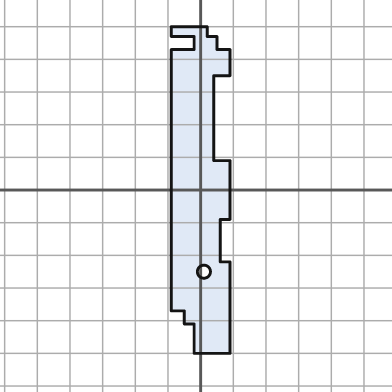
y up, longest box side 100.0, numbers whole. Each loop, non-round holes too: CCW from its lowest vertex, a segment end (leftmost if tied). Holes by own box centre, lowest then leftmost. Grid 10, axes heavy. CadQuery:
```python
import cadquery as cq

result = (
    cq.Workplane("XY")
    .moveTo(-2.0, -50.0)
    .lineTo(9.0, -50.0)
    .lineTo(9.0, -22.0)
    .lineTo(6.0, -22.0)
    .lineTo(6.0, -9.0)
    .lineTo(9.0, -9.0)
    .lineTo(9.0, 9.0)
    .lineTo(4.0, 9.0)
    .lineTo(4.0, 35.0)
    .lineTo(9.0, 35.0)
    .lineTo(9.0, 43.0)
    .lineTo(5.0, 43.0)
    .lineTo(5.0, 47.0)
    .lineTo(2.0, 47.0)
    .lineTo(2.0, 50.0)
    .lineTo(-9.0, 50.0)
    .lineTo(-9.0, 47.0)
    .lineTo(-2.0, 47.0)
    .lineTo(-2.0, 43.0)
    .lineTo(-9.0, 43.0)
    .lineTo(-9.0, -37.0)
    .lineTo(-5.0, -37.0)
    .lineTo(-5.0, -41.0)
    .lineTo(-2.0, -41.0)
    .close()
    .moveTo(1.0, -25.0)
    .circle(2.0)
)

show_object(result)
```